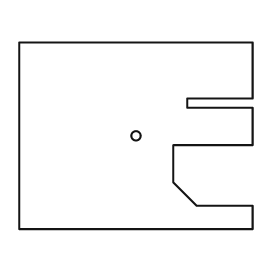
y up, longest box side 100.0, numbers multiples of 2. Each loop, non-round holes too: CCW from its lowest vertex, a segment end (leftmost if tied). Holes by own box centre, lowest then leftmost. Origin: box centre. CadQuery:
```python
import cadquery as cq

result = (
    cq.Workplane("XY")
    .moveTo(-50.0, -40.0)
    .lineTo(50.0, -40.0)
    .lineTo(50.0, -30.0)
    .lineTo(26.0, -30.0)
    .lineTo(16.0, -20.0)
    .lineTo(16.0, -4.0)
    .lineTo(50.0, -4.0)
    .lineTo(50.0, 12.0)
    .lineTo(22.0, 12.0)
    .lineTo(22.0, 16.0)
    .lineTo(50.0, 16.0)
    .lineTo(50.0, 40.0)
    .lineTo(-50.0, 40.0)
    .close()
    .moveTo(0.0, 0.0)
    .circle(2.0)
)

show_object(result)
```